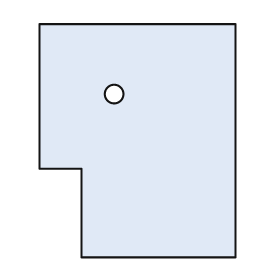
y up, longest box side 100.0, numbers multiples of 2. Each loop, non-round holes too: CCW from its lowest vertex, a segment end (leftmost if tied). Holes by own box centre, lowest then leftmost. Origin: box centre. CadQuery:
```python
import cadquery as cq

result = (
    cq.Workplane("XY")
    .moveTo(-24.0, -50.0)
    .lineTo(42.0, -50.0)
    .lineTo(42.0, 50.0)
    .lineTo(-42.0, 50.0)
    .lineTo(-42.0, -12.0)
    .lineTo(-24.0, -12.0)
    .close()
    .moveTo(-10.0, 20.0)
    .circle(4.0)
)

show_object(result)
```